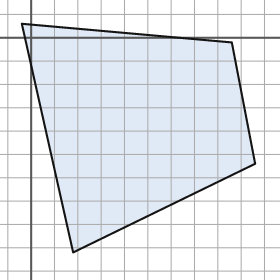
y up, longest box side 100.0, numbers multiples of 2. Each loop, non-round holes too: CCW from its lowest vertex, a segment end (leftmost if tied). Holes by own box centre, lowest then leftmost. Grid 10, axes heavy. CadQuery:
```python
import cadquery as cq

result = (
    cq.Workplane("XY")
    .moveTo(18.0, -92.0)
    .lineTo(96.0, -54.0)
    .lineTo(86.0, -2.0)
    .lineTo(-4.0, 6.0)
    .close()
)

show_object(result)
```